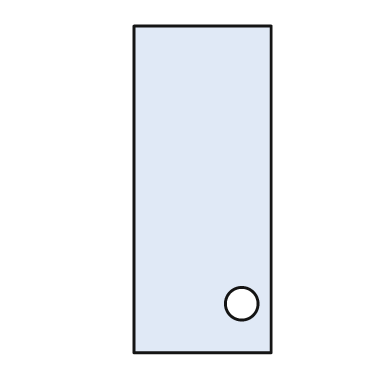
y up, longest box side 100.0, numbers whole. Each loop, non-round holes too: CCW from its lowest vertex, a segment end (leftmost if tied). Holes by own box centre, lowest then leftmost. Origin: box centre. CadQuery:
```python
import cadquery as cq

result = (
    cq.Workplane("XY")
    .moveTo(-21.0, -50.0)
    .lineTo(21.0, -50.0)
    .lineTo(21.0, 50.0)
    .lineTo(-21.0, 50.0)
    .close()
    .moveTo(12.0, -35.0)
    .circle(5.0)
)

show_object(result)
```